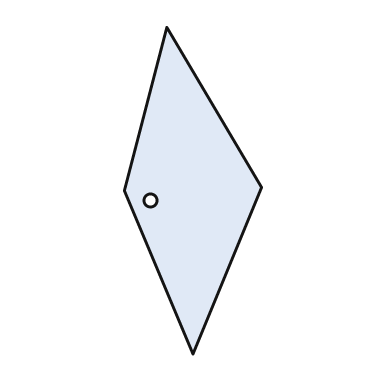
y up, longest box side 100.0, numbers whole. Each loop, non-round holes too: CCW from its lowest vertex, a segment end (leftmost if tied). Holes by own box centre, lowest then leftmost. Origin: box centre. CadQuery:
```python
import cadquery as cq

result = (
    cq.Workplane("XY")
    .moveTo(0.0, -50.0)
    .lineTo(21.0, 1.0)
    .lineTo(-8.0, 50.0)
    .lineTo(-21.0, 0.0)
    .close()
    .moveTo(-13.0, -3.0)
    .circle(2.0)
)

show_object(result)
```